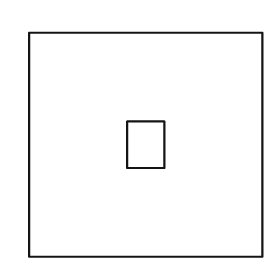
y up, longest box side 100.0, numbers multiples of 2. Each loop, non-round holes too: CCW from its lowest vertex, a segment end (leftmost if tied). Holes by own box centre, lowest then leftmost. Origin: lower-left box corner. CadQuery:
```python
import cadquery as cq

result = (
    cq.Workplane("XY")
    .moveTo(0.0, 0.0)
    .lineTo(100.0, 0.0)
    .lineTo(100.0, 96.0)
    .lineTo(0.0, 96.0)
    .close()
    .moveTo(42.0, 38.0)
    .lineTo(58.0, 38.0)
    .lineTo(58.0, 58.0)
    .lineTo(42.0, 58.0)
    .close()
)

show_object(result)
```